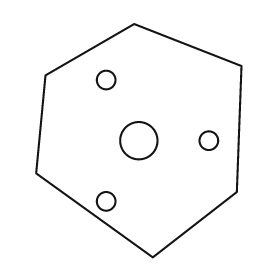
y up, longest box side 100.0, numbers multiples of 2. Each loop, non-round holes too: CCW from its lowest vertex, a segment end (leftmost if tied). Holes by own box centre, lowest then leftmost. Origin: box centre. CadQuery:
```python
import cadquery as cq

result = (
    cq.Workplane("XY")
    .moveTo(6.0, -50.0)
    .lineTo(42.0, -22.0)
    .lineTo(44.0, 32.0)
    .lineTo(-2.0, 50.0)
    .lineTo(-40.0, 28.0)
    .lineTo(-44.0, -14.0)
    .close()
    .moveTo(-14.0, -26.0)
    .circle(4.0)
    .moveTo(0.0, 0.0)
    .circle(8.0)
    .moveTo(30.0, 0.0)
    .circle(4.0)
    .moveTo(-14.0, 26.0)
    .circle(4.0)
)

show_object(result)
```